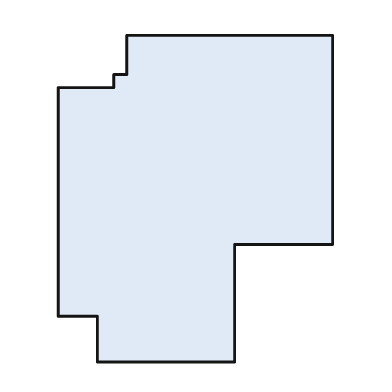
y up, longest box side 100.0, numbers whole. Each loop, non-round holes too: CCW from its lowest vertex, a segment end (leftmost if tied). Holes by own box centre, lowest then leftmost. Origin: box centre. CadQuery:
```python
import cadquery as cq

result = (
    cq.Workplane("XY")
    .moveTo(-30.0, -50.0)
    .lineTo(12.0, -50.0)
    .lineTo(12.0, -14.0)
    .lineTo(42.0, -14.0)
    .lineTo(42.0, 50.0)
    .lineTo(-21.0, 50.0)
    .lineTo(-21.0, 38.0)
    .lineTo(-25.0, 38.0)
    .lineTo(-25.0, 34.0)
    .lineTo(-42.0, 34.0)
    .lineTo(-42.0, -36.0)
    .lineTo(-30.0, -36.0)
    .close()
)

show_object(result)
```